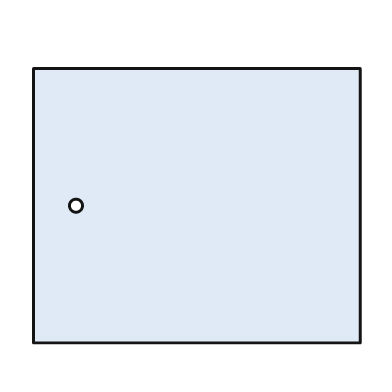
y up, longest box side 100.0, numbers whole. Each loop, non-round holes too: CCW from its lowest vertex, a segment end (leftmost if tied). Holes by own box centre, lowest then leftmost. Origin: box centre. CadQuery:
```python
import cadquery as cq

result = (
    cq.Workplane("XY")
    .moveTo(-50.0, -42.0)
    .lineTo(50.0, -42.0)
    .lineTo(50.0, 42.0)
    .lineTo(-50.0, 42.0)
    .close()
    .moveTo(-37.0, 0.0)
    .circle(2.0)
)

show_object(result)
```